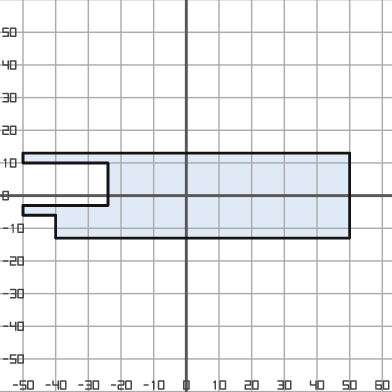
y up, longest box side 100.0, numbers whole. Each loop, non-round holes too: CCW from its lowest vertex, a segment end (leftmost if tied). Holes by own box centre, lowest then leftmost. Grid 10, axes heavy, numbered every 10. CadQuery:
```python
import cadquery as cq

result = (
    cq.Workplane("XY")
    .moveTo(-40.0, -13.0)
    .lineTo(50.0, -13.0)
    .lineTo(50.0, 13.0)
    .lineTo(-50.0, 13.0)
    .lineTo(-50.0, 10.0)
    .lineTo(-24.0, 10.0)
    .lineTo(-24.0, -3.0)
    .lineTo(-50.0, -3.0)
    .lineTo(-50.0, -6.0)
    .lineTo(-40.0, -6.0)
    .close()
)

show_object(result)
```